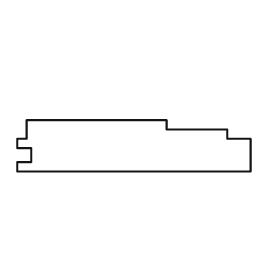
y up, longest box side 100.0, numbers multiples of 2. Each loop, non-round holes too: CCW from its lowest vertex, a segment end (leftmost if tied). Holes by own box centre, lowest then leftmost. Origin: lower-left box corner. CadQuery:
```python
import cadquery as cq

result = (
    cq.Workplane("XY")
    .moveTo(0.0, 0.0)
    .lineTo(100.0, 0.0)
    .lineTo(100.0, 14.0)
    .lineTo(90.0, 14.0)
    .lineTo(90.0, 18.0)
    .lineTo(64.0, 18.0)
    .lineTo(64.0, 22.0)
    .lineTo(4.0, 22.0)
    .lineTo(4.0, 14.0)
    .lineTo(0.0, 14.0)
    .lineTo(0.0, 10.0)
    .lineTo(6.0, 10.0)
    .lineTo(6.0, 4.0)
    .lineTo(0.0, 4.0)
    .close()
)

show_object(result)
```